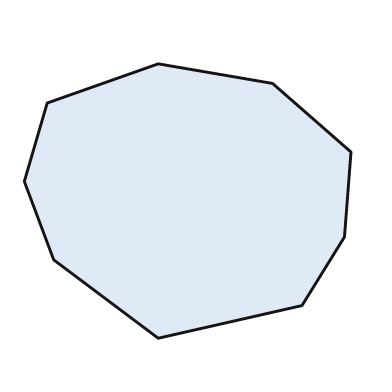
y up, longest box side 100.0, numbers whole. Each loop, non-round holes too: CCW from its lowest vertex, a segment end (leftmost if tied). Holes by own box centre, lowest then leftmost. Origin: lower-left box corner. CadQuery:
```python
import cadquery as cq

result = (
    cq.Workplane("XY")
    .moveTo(41.0, 0.0)
    .lineTo(85.0, 10.0)
    .lineTo(98.0, 31.0)
    .lineTo(100.0, 57.0)
    .lineTo(76.0, 78.0)
    .lineTo(41.0, 84.0)
    .lineTo(7.0, 72.0)
    .lineTo(0.0, 48.0)
    .lineTo(9.0, 24.0)
    .close()
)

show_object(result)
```